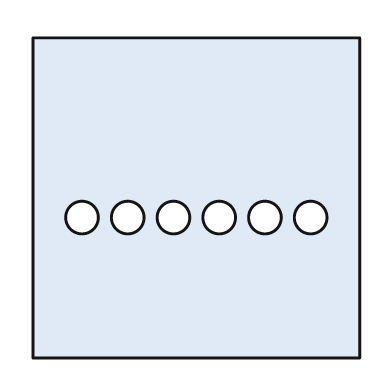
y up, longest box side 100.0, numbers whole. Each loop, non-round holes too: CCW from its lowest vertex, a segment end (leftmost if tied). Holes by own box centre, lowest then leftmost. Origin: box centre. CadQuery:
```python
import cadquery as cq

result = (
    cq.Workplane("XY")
    .moveTo(-50.0, -49.0)
    .lineTo(50.0, -49.0)
    .lineTo(50.0, 49.0)
    .lineTo(-50.0, 49.0)
    .close()
    .moveTo(-35.0, -6.0)
    .circle(5.0)
    .moveTo(-21.0, -6.0)
    .circle(5.0)
    .moveTo(-7.0, -6.0)
    .circle(5.0)
    .moveTo(7.0, -6.0)
    .circle(5.0)
    .moveTo(21.0, -6.0)
    .circle(5.0)
    .moveTo(35.0, -6.0)
    .circle(5.0)
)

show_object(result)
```